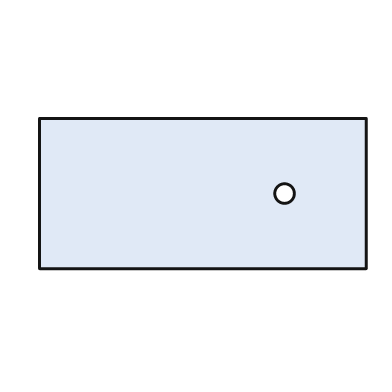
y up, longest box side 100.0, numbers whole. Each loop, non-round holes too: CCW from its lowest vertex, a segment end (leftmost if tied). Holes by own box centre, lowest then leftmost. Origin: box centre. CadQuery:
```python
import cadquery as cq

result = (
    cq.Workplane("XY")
    .moveTo(-50.0, -23.0)
    .lineTo(50.0, -23.0)
    .lineTo(50.0, 23.0)
    .lineTo(-50.0, 23.0)
    .close()
    .moveTo(25.0, 0.0)
    .circle(3.0)
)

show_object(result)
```